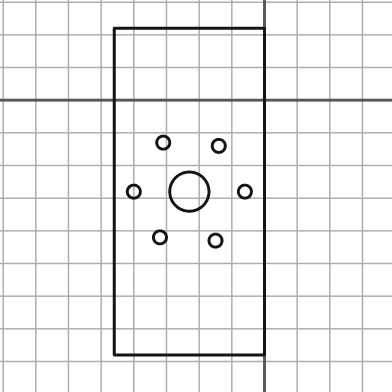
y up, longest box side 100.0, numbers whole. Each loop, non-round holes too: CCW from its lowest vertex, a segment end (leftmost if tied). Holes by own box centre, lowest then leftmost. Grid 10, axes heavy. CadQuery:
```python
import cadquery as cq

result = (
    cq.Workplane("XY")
    .moveTo(-46.0, -78.0)
    .lineTo(0.0, -78.0)
    .lineTo(0.0, 22.0)
    .lineTo(-46.0, 22.0)
    .close()
    .moveTo(-15.0, -43.0)
    .circle(2.0)
    .moveTo(-32.0, -42.0)
    .circle(2.0)
    .moveTo(-40.0, -28.0)
    .circle(2.0)
    .moveTo(-23.0, -28.0)
    .circle(6.0)
    .moveTo(-6.0, -28.0)
    .circle(2.0)
    .moveTo(-14.0, -14.0)
    .circle(2.0)
    .moveTo(-31.0, -13.0)
    .circle(2.0)
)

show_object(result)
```